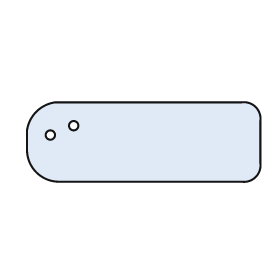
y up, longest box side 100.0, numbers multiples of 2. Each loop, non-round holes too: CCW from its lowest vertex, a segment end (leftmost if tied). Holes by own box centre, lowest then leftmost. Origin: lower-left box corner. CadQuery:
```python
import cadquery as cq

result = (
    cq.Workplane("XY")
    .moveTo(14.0, 0.0)
    .lineTo(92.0, 0.0)
    .threePointArc((98.0, 2.0), (100.0, 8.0))
    .lineTo(100.0, 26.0)
    .threePointArc((98.0, 32.0), (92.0, 34.0))
    .lineTo(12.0, 34.0)
    .threePointArc((4.0, 30.0), (0.0, 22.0))
    .lineTo(0.0, 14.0)
    .threePointArc((4.0, 4.0), (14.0, 0.0))
    .close()
    .moveTo(10.0, 20.0)
    .circle(2.0)
    .moveTo(20.0, 24.0)
    .circle(2.0)
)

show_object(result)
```